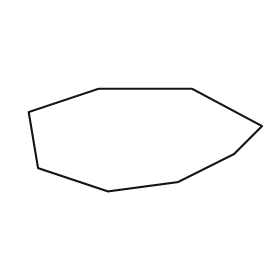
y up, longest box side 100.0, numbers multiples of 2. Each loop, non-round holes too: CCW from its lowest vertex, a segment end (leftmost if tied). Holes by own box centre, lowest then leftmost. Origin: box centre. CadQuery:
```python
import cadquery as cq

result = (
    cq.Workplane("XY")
    .moveTo(-16.0, -22.0)
    .lineTo(14.0, -18.0)
    .lineTo(38.0, -6.0)
    .lineTo(50.0, 6.0)
    .lineTo(20.0, 22.0)
    .lineTo(-20.0, 22.0)
    .lineTo(-50.0, 12.0)
    .lineTo(-46.0, -12.0)
    .close()
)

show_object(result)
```